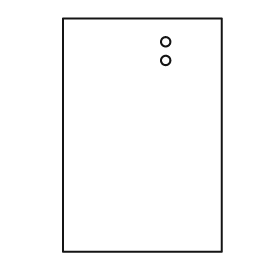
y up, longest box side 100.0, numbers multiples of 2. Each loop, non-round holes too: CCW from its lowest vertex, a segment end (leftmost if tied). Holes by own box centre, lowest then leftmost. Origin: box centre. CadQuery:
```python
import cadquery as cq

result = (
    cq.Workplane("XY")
    .moveTo(-34.0, -50.0)
    .lineTo(34.0, -50.0)
    .lineTo(34.0, 50.0)
    .lineTo(-34.0, 50.0)
    .close()
    .moveTo(10.0, 32.0)
    .circle(2.0)
    .moveTo(10.0, 40.0)
    .circle(2.0)
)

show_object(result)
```